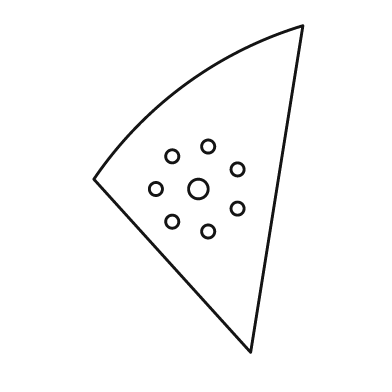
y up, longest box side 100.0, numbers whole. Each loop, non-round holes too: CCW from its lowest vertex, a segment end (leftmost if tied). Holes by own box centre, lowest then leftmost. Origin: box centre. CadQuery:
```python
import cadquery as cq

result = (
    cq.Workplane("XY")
    .moveTo(16.0, -50.0)
    .lineTo(32.0, 50.0)
    .threePointArc((-4.0, 32.0), (-32.0, 3.0))
    .close()
    .moveTo(3.0, -13.0)
    .circle(2.0)
    .moveTo(-8.0, -10.0)
    .circle(2.0)
    .moveTo(12.0, -6.0)
    .circle(2.0)
    .moveTo(-13.0, 0.0)
    .circle(2.0)
    .moveTo(0.0, 0.0)
    .circle(3.0)
    .moveTo(12.0, 6.0)
    .circle(2.0)
    .moveTo(-8.0, 10.0)
    .circle(2.0)
    .moveTo(3.0, 13.0)
    .circle(2.0)
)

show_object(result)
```